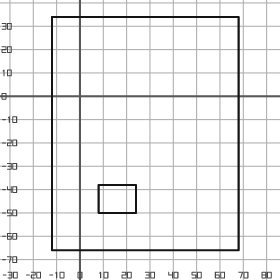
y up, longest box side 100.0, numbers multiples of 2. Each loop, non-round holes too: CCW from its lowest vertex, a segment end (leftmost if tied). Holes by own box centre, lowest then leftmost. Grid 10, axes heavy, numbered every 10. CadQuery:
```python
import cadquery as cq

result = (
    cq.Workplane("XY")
    .moveTo(-12.0, -66.0)
    .lineTo(68.0, -66.0)
    .lineTo(68.0, 34.0)
    .lineTo(-12.0, 34.0)
    .close()
    .moveTo(8.0, -50.0)
    .lineTo(24.0, -50.0)
    .lineTo(24.0, -38.0)
    .lineTo(8.0, -38.0)
    .close()
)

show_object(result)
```